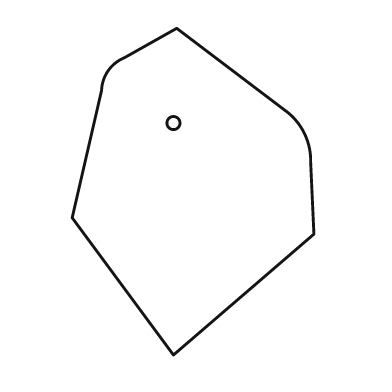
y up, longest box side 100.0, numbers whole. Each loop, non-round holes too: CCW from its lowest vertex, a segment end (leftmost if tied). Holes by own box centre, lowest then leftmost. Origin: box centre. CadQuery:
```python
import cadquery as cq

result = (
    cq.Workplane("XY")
    .moveTo(-6.0, -50.0)
    .lineTo(37.0, -13.0)
    .lineTo(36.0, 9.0)
    .threePointArc((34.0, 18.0), (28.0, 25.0))
    .lineTo(-5.0, 50.0)
    .lineTo(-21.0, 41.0)
    .threePointArc((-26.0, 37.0), (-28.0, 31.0))
    .lineTo(-37.0, -8.0)
    .close()
    .moveTo(-6.0, 21.0)
    .circle(2.0)
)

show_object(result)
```